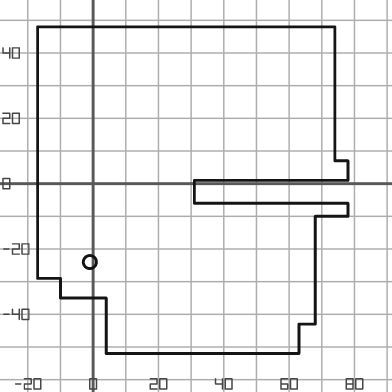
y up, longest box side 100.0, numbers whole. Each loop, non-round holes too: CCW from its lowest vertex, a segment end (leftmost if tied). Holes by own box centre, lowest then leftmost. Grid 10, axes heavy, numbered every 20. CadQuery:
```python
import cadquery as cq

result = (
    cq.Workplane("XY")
    .moveTo(4.0, -52.0)
    .lineTo(63.0, -52.0)
    .lineTo(63.0, -43.0)
    .lineTo(68.0, -43.0)
    .lineTo(68.0, -10.0)
    .lineTo(78.0, -10.0)
    .lineTo(78.0, -6.0)
    .lineTo(31.0, -6.0)
    .lineTo(31.0, 1.0)
    .lineTo(78.0, 1.0)
    .lineTo(78.0, 7.0)
    .lineTo(74.0, 7.0)
    .lineTo(74.0, 48.0)
    .lineTo(-17.0, 48.0)
    .lineTo(-17.0, -29.0)
    .lineTo(-10.0, -29.0)
    .lineTo(-10.0, -35.0)
    .lineTo(4.0, -35.0)
    .close()
    .moveTo(-1.0, -24.0)
    .circle(2.0)
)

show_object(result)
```